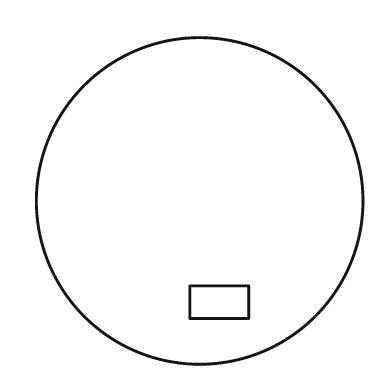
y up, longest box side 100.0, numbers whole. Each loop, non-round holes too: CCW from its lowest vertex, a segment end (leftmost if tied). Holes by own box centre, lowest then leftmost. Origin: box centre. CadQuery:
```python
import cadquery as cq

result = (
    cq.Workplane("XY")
    .moveTo(0.0, 0.0)
    .circle(50.0)
    .moveTo(-3.0, -36.0)
    .lineTo(15.0, -36.0)
    .lineTo(15.0, -26.0)
    .lineTo(-3.0, -26.0)
    .close()
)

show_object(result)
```